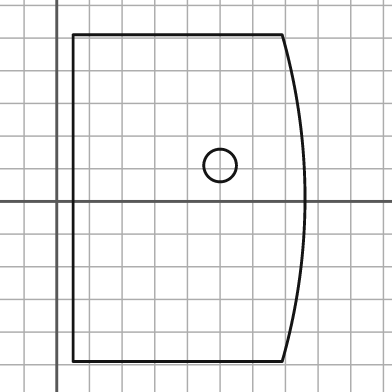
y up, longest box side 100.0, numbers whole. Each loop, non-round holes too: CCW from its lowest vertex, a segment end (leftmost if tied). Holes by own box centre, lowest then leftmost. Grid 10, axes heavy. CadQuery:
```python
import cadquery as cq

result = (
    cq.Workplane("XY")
    .moveTo(5.0, -49.0)
    .lineTo(69.0, -49.0)
    .threePointArc((76.0, 1.0), (69.0, 51.0))
    .lineTo(5.0, 51.0)
    .close()
    .moveTo(50.0, 11.0)
    .circle(5.0)
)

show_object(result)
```